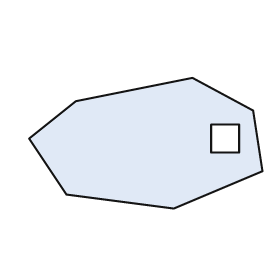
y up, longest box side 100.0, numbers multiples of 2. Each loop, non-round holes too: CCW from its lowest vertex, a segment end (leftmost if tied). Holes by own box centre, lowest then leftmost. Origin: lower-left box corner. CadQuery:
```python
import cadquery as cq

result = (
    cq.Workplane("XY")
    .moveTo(62.0, 0.0)
    .lineTo(100.0, 16.0)
    .lineTo(96.0, 42.0)
    .lineTo(70.0, 56.0)
    .lineTo(20.0, 46.0)
    .lineTo(0.0, 30.0)
    .lineTo(16.0, 6.0)
    .close()
    .moveTo(78.0, 24.0)
    .lineTo(90.0, 24.0)
    .lineTo(90.0, 36.0)
    .lineTo(78.0, 36.0)
    .close()
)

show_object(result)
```